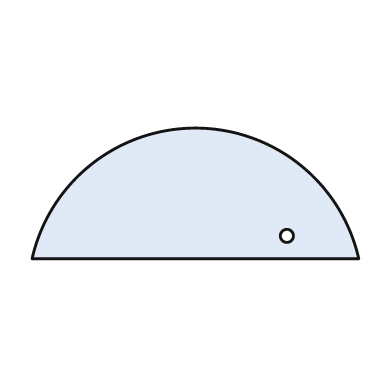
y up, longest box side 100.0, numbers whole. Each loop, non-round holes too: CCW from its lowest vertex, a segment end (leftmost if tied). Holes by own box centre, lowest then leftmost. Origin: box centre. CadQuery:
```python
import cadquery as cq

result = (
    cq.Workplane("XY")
    .moveTo(-50.0, -20.0)
    .lineTo(50.0, -20.0)
    .threePointArc((0.0, 20.0), (-50.0, -20.0))
    .close()
    .moveTo(28.0, -13.0)
    .circle(2.0)
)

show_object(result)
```